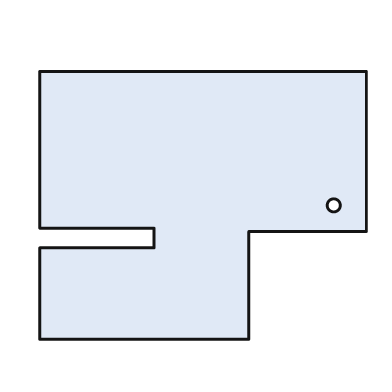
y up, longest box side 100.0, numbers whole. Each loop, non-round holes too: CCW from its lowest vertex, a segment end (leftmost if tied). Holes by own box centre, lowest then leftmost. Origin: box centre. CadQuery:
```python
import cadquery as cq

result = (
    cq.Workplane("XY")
    .moveTo(-50.0, -41.0)
    .lineTo(14.0, -41.0)
    .lineTo(14.0, -8.0)
    .lineTo(50.0, -8.0)
    .lineTo(50.0, 41.0)
    .lineTo(-50.0, 41.0)
    .lineTo(-50.0, -7.0)
    .lineTo(-15.0, -7.0)
    .lineTo(-15.0, -13.0)
    .lineTo(-50.0, -13.0)
    .close()
    .moveTo(40.0, 0.0)
    .circle(2.0)
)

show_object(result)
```